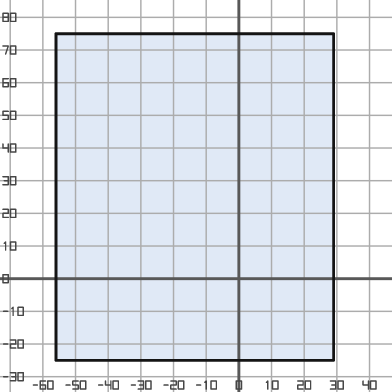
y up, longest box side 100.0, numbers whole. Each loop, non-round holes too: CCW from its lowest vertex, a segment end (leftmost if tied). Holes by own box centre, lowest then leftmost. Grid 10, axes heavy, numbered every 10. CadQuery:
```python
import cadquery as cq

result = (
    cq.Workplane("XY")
    .moveTo(-56.0, -25.0)
    .lineTo(29.0, -25.0)
    .lineTo(29.0, 75.0)
    .lineTo(-56.0, 75.0)
    .close()
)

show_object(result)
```